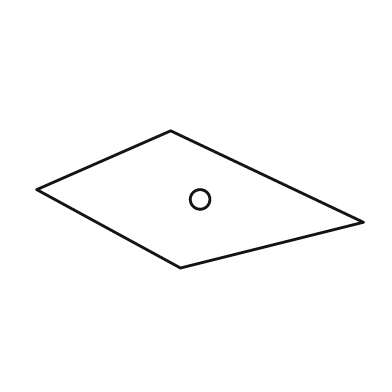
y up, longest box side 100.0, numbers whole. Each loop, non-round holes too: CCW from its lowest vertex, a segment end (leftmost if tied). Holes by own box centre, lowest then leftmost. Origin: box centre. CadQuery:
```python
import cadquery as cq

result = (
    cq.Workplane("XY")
    .moveTo(-6.0, -21.0)
    .lineTo(50.0, -7.0)
    .lineTo(-9.0, 21.0)
    .lineTo(-50.0, 3.0)
    .close()
    .moveTo(0.0, 0.0)
    .circle(3.0)
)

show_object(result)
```